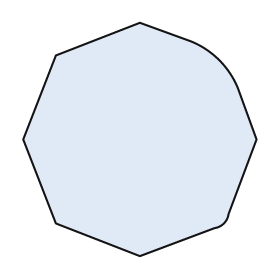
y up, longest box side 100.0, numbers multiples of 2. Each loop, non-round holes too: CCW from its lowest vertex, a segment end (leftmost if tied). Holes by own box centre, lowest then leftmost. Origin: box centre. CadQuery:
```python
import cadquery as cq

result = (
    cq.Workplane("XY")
    .moveTo(0.0, -50.0)
    .lineTo(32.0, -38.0)
    .threePointArc((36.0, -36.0), (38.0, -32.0))
    .lineTo(50.0, 0.0)
    .lineTo(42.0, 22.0)
    .threePointArc((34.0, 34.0), (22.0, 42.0))
    .lineTo(0.0, 50.0)
    .lineTo(-36.0, 36.0)
    .lineTo(-50.0, 0.0)
    .lineTo(-36.0, -36.0)
    .close()
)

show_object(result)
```